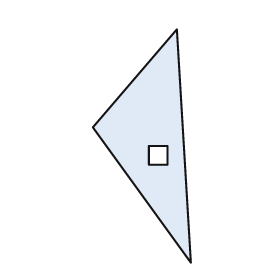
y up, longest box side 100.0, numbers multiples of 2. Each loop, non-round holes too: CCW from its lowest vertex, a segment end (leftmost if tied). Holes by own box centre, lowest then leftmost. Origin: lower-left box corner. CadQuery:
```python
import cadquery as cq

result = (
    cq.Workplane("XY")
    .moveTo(42.0, 0.0)
    .lineTo(36.0, 100.0)
    .lineTo(0.0, 58.0)
    .close()
    .moveTo(24.0, 42.0)
    .lineTo(32.0, 42.0)
    .lineTo(32.0, 50.0)
    .lineTo(24.0, 50.0)
    .close()
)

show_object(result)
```